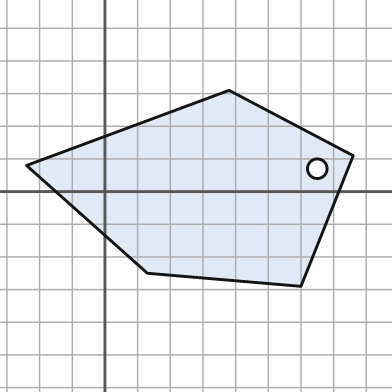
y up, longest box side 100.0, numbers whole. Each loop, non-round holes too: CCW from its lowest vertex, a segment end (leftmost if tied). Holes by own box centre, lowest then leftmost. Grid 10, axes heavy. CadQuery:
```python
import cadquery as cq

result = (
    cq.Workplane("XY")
    .moveTo(60.0, -29.0)
    .lineTo(76.0, 11.0)
    .lineTo(38.0, 31.0)
    .lineTo(-24.0, 8.0)
    .lineTo(13.0, -25.0)
    .close()
    .moveTo(65.0, 7.0)
    .circle(3.0)
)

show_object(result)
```